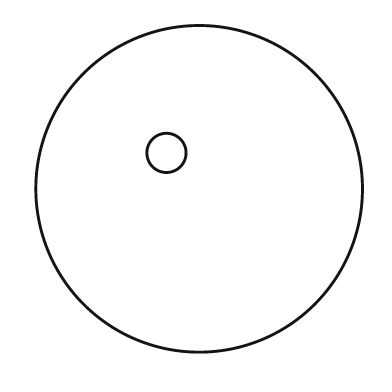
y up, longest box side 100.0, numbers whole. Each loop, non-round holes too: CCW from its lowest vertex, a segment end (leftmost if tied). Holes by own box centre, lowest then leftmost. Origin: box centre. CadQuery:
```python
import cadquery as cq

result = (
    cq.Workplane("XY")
    .moveTo(0.0, 0.0)
    .circle(50.0)
    .moveTo(-10.0, 11.0)
    .circle(6.0)
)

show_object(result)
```